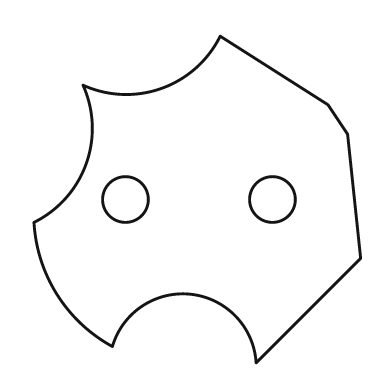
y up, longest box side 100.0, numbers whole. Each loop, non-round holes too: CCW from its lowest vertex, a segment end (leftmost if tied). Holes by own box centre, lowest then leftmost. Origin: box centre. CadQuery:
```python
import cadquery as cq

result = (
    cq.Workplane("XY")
    .moveTo(18.0, -50.0)
    .lineTo(50.0, -18.0)
    .lineTo(46.0, 20.0)
    .lineTo(40.0, 29.0)
    .lineTo(7.0, 50.0)
    .threePointArc((-11.0, 34.0), (-35.0, 35.0))
    .threePointArc((-34.0, 11.0), (-50.0, -7.0))
    .threePointArc((-43.0, -29.0), (-26.0, -45.0))
    .threePointArc((-2.0, -29.0), (18.0, -50.0))
    .close()
    .moveTo(-22.0, 0.0)
    .circle(7.0)
    .moveTo(23.0, 0.0)
    .circle(7.0)
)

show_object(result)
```